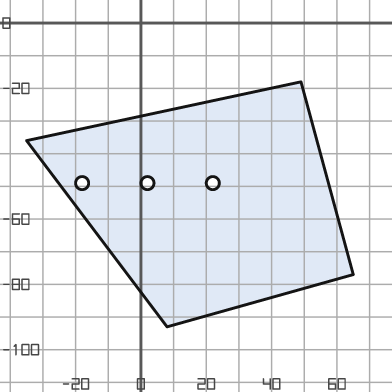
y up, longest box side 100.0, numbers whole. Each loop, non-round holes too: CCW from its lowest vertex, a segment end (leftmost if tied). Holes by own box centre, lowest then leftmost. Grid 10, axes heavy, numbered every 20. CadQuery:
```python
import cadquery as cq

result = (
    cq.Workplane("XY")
    .moveTo(8.0, -93.0)
    .lineTo(65.0, -77.0)
    .lineTo(49.0, -18.0)
    .lineTo(-35.0, -36.0)
    .close()
    .moveTo(-18.0, -49.0)
    .circle(2.0)
    .moveTo(2.0, -49.0)
    .circle(2.0)
    .moveTo(22.0, -49.0)
    .circle(2.0)
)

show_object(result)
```